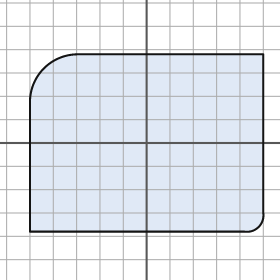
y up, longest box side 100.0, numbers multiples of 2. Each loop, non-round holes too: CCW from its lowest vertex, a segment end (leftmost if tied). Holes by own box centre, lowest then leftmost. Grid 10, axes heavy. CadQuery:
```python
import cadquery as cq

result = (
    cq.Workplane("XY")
    .moveTo(-50.0, -38.0)
    .lineTo(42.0, -38.0)
    .threePointArc((48.0, -36.0), (50.0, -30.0))
    .lineTo(50.0, 38.0)
    .lineTo(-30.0, 38.0)
    .threePointArc((-44.0, 32.0), (-50.0, 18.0))
    .close()
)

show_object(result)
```